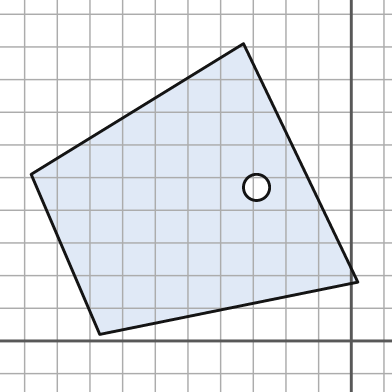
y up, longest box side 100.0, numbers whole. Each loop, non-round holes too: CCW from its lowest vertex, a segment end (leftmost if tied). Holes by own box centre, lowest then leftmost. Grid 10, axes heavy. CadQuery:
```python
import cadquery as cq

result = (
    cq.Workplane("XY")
    .moveTo(-77.0, 2.0)
    .lineTo(2.0, 18.0)
    .lineTo(-33.0, 91.0)
    .lineTo(-98.0, 51.0)
    .close()
    .moveTo(-29.0, 47.0)
    .circle(4.0)
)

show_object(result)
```